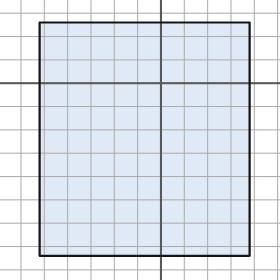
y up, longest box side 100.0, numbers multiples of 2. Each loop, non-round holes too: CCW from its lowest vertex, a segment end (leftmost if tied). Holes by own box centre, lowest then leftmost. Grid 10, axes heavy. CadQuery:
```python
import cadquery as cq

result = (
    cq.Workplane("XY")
    .moveTo(-52.0, -74.0)
    .lineTo(38.0, -74.0)
    .lineTo(38.0, 26.0)
    .lineTo(-52.0, 26.0)
    .close()
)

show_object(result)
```